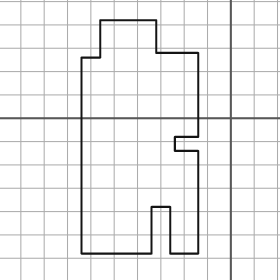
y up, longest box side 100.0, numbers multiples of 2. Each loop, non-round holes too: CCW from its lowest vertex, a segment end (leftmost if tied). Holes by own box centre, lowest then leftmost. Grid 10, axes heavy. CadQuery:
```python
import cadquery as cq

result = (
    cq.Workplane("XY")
    .moveTo(-64.0, -58.0)
    .lineTo(-34.0, -58.0)
    .lineTo(-34.0, -38.0)
    .lineTo(-26.0, -38.0)
    .lineTo(-26.0, -58.0)
    .lineTo(-14.0, -58.0)
    .lineTo(-14.0, -14.0)
    .lineTo(-24.0, -14.0)
    .lineTo(-24.0, -8.0)
    .lineTo(-14.0, -8.0)
    .lineTo(-14.0, 28.0)
    .lineTo(-32.0, 28.0)
    .lineTo(-32.0, 42.0)
    .lineTo(-56.0, 42.0)
    .lineTo(-56.0, 26.0)
    .lineTo(-64.0, 26.0)
    .close()
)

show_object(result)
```